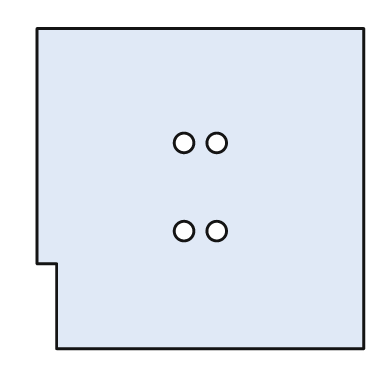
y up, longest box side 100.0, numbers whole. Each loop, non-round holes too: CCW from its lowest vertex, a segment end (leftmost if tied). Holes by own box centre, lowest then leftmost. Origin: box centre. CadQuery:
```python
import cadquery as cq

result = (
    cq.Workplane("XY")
    .moveTo(-44.0, -49.0)
    .lineTo(50.0, -49.0)
    .lineTo(50.0, 49.0)
    .lineTo(-50.0, 49.0)
    .lineTo(-50.0, -23.0)
    .lineTo(-44.0, -23.0)
    .close()
    .moveTo(-5.0, -13.0)
    .circle(3.0)
    .moveTo(5.0, -13.0)
    .circle(3.0)
    .moveTo(-5.0, 14.0)
    .circle(3.0)
    .moveTo(5.0, 14.0)
    .circle(3.0)
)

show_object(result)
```